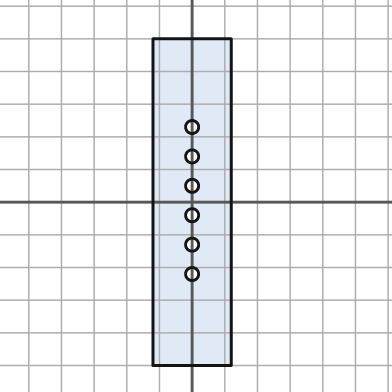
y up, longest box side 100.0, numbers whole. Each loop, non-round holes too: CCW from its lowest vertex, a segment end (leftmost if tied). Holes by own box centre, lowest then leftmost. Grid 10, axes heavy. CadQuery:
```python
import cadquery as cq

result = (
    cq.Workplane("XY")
    .moveTo(-12.0, -50.0)
    .lineTo(12.0, -50.0)
    .lineTo(12.0, 50.0)
    .lineTo(-12.0, 50.0)
    .close()
    .moveTo(0.0, -22.0)
    .circle(2.0)
    .moveTo(0.0, -13.0)
    .circle(2.0)
    .moveTo(0.0, -4.0)
    .circle(2.0)
    .moveTo(0.0, 5.0)
    .circle(2.0)
    .moveTo(0.0, 14.0)
    .circle(2.0)
    .moveTo(0.0, 23.0)
    .circle(2.0)
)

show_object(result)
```